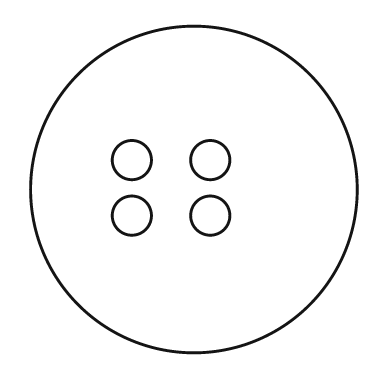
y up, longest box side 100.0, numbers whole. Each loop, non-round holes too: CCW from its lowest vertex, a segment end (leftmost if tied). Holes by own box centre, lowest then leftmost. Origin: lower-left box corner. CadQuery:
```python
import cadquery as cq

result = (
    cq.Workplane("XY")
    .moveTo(50.0, 50.0)
    .circle(50.0)
    .moveTo(31.0, 42.0)
    .circle(6.0)
    .moveTo(55.0, 42.0)
    .circle(6.0)
    .moveTo(31.0, 59.0)
    .circle(6.0)
    .moveTo(55.0, 59.0)
    .circle(6.0)
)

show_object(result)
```